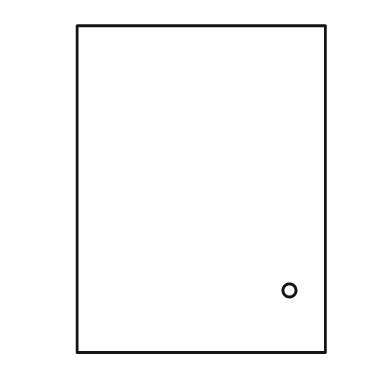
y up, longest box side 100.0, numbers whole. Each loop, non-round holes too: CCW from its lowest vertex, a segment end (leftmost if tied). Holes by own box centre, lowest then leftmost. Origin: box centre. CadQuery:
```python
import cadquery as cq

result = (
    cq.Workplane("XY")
    .moveTo(-38.0, -50.0)
    .lineTo(38.0, -50.0)
    .lineTo(38.0, 50.0)
    .lineTo(-38.0, 50.0)
    .close()
    .moveTo(27.0, -31.0)
    .circle(2.0)
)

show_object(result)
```